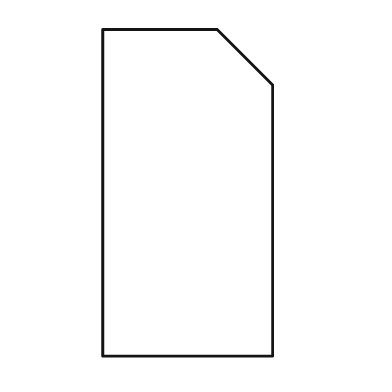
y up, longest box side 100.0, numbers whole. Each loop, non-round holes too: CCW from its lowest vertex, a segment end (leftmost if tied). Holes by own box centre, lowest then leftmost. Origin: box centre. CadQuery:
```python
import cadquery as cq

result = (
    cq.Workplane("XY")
    .moveTo(-26.0, -50.0)
    .lineTo(26.0, -50.0)
    .lineTo(26.0, 33.0)
    .lineTo(9.0, 50.0)
    .lineTo(-26.0, 50.0)
    .close()
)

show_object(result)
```